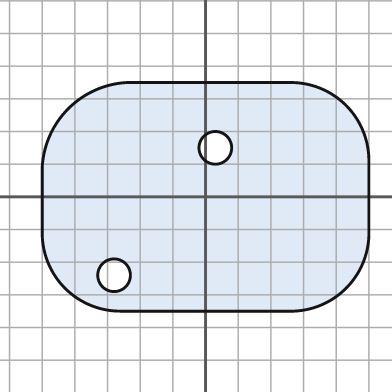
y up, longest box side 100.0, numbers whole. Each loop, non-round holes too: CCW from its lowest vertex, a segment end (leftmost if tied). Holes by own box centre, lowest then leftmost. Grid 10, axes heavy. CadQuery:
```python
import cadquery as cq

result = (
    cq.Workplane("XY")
    .moveTo(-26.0, -35.0)
    .lineTo(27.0, -35.0)
    .threePointArc((43.0, -28.0), (50.0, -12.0))
    .lineTo(50.0, 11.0)
    .threePointArc((43.0, 28.0), (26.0, 35.0))
    .lineTo(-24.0, 35.0)
    .threePointArc((-42.0, 27.0), (-50.0, 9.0))
    .lineTo(-50.0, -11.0)
    .threePointArc((-43.0, -28.0), (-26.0, -35.0))
    .close()
    .moveTo(-28.0, -24.0)
    .circle(5.0)
    .moveTo(3.0, 15.0)
    .circle(5.0)
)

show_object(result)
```